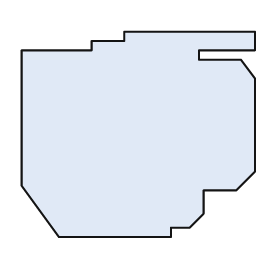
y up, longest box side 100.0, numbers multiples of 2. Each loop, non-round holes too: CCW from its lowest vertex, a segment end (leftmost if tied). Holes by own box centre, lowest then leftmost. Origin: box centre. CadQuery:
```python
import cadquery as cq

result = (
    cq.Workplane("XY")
    .moveTo(-34.0, -44.0)
    .lineTo(14.0, -44.0)
    .lineTo(14.0, -40.0)
    .lineTo(22.0, -40.0)
    .lineTo(28.0, -34.0)
    .lineTo(28.0, -24.0)
    .lineTo(42.0, -24.0)
    .lineTo(50.0, -16.0)
    .lineTo(50.0, 24.0)
    .lineTo(44.0, 32.0)
    .lineTo(26.0, 32.0)
    .lineTo(26.0, 36.0)
    .lineTo(50.0, 36.0)
    .lineTo(50.0, 44.0)
    .lineTo(-6.0, 44.0)
    .lineTo(-6.0, 40.0)
    .lineTo(-20.0, 40.0)
    .lineTo(-20.0, 36.0)
    .lineTo(-50.0, 36.0)
    .lineTo(-50.0, -22.0)
    .close()
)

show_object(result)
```